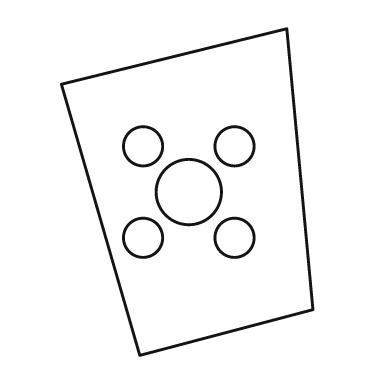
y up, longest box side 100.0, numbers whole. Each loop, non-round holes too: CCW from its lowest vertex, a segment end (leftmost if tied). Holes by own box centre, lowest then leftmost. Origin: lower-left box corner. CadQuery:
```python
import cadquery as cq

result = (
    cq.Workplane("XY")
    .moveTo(24.0, 0.0)
    .lineTo(77.0, 14.0)
    .lineTo(69.0, 100.0)
    .lineTo(0.0, 83.0)
    .close()
    .moveTo(25.0, 36.0)
    .circle(6.0)
    .moveTo(53.0, 36.0)
    .circle(6.0)
    .moveTo(39.0, 50.0)
    .circle(10.0)
    .moveTo(25.0, 64.0)
    .circle(6.0)
    .moveTo(53.0, 64.0)
    .circle(6.0)
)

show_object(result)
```